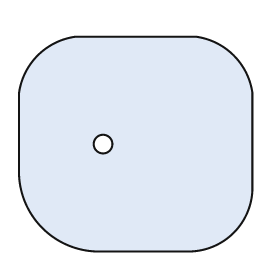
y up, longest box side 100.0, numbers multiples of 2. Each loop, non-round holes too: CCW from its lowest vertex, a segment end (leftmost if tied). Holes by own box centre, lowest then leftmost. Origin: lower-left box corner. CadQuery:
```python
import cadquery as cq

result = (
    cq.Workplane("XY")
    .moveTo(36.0, 0.0)
    .lineTo(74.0, 0.0)
    .threePointArc((92.0, 8.0), (100.0, 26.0))
    .lineTo(100.0, 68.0)
    .threePointArc((92.0, 84.0), (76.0, 92.0))
    .lineTo(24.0, 92.0)
    .threePointArc((8.0, 84.0), (0.0, 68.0))
    .lineTo(0.0, 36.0)
    .threePointArc((10.0, 10.0), (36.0, 0.0))
    .close()
    .moveTo(36.0, 46.0)
    .circle(4.0)
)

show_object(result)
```